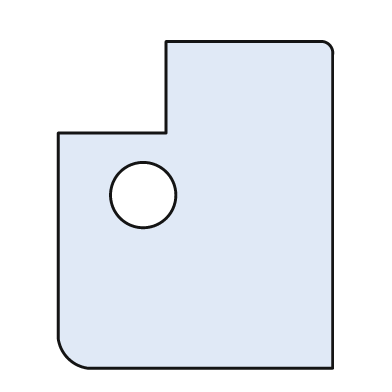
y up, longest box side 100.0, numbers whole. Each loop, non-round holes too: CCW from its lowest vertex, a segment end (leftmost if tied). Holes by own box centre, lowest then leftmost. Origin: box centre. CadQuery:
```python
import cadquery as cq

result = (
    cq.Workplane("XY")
    .moveTo(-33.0, -50.0)
    .lineTo(42.0, -50.0)
    .lineTo(42.0, 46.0)
    .threePointArc((41.0, 49.0), (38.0, 50.0))
    .lineTo(-9.0, 50.0)
    .lineTo(-9.0, 22.0)
    .lineTo(-42.0, 22.0)
    .lineTo(-42.0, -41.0)
    .threePointArc((-39.0, -47.0), (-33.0, -50.0))
    .close()
    .moveTo(-16.0, 3.0)
    .circle(10.0)
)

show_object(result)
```